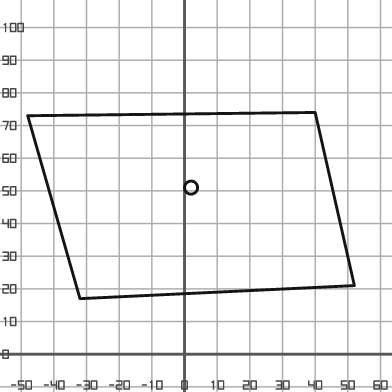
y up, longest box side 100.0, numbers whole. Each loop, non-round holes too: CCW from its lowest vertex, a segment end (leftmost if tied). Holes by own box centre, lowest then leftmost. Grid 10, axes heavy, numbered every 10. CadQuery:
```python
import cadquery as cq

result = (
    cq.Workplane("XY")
    .moveTo(-32.0, 17.0)
    .lineTo(52.0, 21.0)
    .lineTo(40.0, 74.0)
    .lineTo(-48.0, 73.0)
    .close()
    .moveTo(2.0, 51.0)
    .circle(2.0)
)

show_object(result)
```